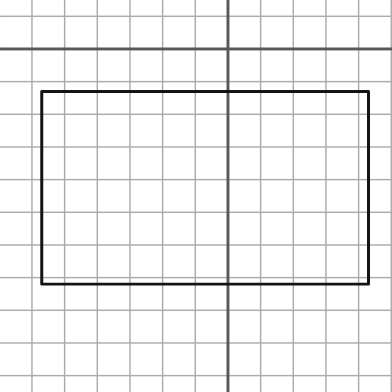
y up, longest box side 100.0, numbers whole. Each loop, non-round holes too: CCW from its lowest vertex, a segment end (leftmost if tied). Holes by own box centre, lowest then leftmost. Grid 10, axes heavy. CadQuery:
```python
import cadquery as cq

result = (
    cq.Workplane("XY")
    .moveTo(-57.0, -72.0)
    .lineTo(43.0, -72.0)
    .lineTo(43.0, -13.0)
    .lineTo(-57.0, -13.0)
    .close()
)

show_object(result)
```